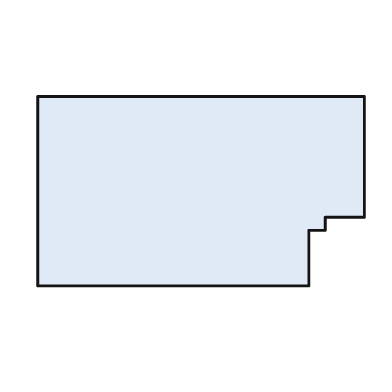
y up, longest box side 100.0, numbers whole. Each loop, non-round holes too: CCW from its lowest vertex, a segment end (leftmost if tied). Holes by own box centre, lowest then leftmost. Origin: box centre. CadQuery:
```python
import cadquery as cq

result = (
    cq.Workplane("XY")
    .moveTo(-50.0, -29.0)
    .lineTo(33.0, -29.0)
    .lineTo(33.0, -12.0)
    .lineTo(38.0, -12.0)
    .lineTo(38.0, -8.0)
    .lineTo(50.0, -8.0)
    .lineTo(50.0, 29.0)
    .lineTo(-50.0, 29.0)
    .close()
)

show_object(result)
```